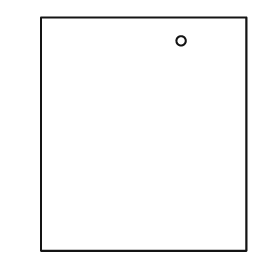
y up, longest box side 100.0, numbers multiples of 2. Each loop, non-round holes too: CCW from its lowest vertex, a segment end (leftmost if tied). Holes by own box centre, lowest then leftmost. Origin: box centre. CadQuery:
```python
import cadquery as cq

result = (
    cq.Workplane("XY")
    .moveTo(-44.0, -50.0)
    .lineTo(44.0, -50.0)
    .lineTo(44.0, 50.0)
    .lineTo(-44.0, 50.0)
    .close()
    .moveTo(16.0, 40.0)
    .circle(2.0)
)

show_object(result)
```